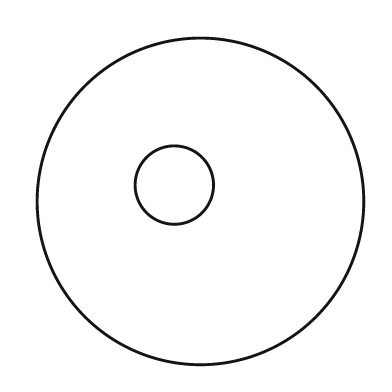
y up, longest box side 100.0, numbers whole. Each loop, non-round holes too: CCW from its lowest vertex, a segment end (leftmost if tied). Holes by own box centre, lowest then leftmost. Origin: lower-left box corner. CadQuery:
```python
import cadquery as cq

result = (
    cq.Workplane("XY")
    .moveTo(50.0, 50.0)
    .circle(50.0)
    .moveTo(42.0, 55.0)
    .circle(12.0)
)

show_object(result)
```